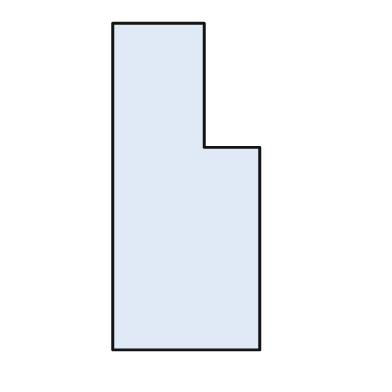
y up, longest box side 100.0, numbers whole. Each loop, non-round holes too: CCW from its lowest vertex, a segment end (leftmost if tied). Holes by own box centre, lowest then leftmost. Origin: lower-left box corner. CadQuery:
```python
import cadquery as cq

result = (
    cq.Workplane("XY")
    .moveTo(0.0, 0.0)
    .lineTo(45.0, 0.0)
    .lineTo(45.0, 62.0)
    .lineTo(28.0, 62.0)
    .lineTo(28.0, 100.0)
    .lineTo(0.0, 100.0)
    .close()
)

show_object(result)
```